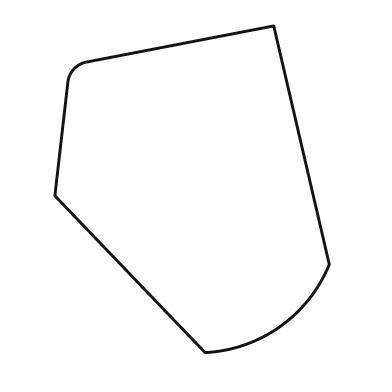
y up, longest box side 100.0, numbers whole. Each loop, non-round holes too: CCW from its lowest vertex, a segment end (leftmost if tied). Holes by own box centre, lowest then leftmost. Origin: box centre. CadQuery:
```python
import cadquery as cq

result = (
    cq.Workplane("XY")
    .moveTo(4.0, -50.0)
    .threePointArc((27.0, -42.0), (42.0, -23.0))
    .lineTo(25.0, 50.0)
    .lineTo(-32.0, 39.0)
    .threePointArc((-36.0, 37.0), (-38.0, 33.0))
    .lineTo(-42.0, -2.0)
    .close()
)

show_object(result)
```